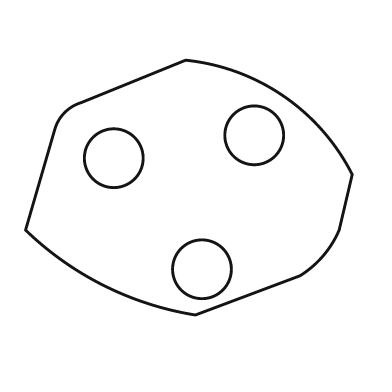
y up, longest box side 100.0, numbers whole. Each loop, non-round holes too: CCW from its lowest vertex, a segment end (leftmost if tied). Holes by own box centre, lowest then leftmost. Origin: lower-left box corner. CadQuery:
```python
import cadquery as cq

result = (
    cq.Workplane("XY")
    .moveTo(52.0, 0.0)
    .lineTo(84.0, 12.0)
    .threePointArc((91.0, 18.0), (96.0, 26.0))
    .lineTo(100.0, 43.0)
    .threePointArc((79.0, 67.0), (49.0, 78.0))
    .lineTo(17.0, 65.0)
    .threePointArc((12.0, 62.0), (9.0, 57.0))
    .lineTo(0.0, 26.0)
    .threePointArc((24.0, 9.0), (52.0, 0.0))
    .close()
    .moveTo(54.0, 14.0)
    .circle(9.0)
    .moveTo(27.0, 48.0)
    .circle(9.0)
    .moveTo(70.0, 55.0)
    .circle(9.0)
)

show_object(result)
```